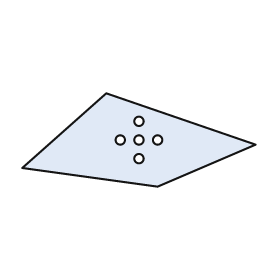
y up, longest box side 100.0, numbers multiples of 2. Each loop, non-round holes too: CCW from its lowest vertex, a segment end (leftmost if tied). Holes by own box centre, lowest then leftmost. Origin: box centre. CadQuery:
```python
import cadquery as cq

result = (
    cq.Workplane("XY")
    .moveTo(8.0, -20.0)
    .lineTo(50.0, -2.0)
    .lineTo(-14.0, 20.0)
    .lineTo(-50.0, -12.0)
    .close()
    .moveTo(0.0, -8.0)
    .circle(2.0)
    .moveTo(-8.0, 0.0)
    .circle(2.0)
    .moveTo(0.0, 0.0)
    .circle(2.0)
    .moveTo(8.0, 0.0)
    .circle(2.0)
    .moveTo(0.0, 8.0)
    .circle(2.0)
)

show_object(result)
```